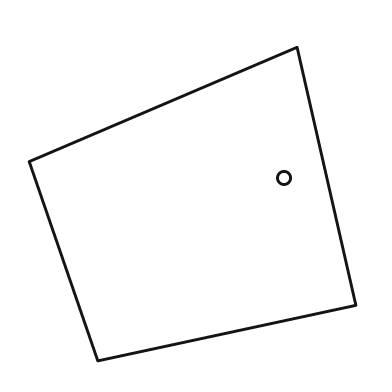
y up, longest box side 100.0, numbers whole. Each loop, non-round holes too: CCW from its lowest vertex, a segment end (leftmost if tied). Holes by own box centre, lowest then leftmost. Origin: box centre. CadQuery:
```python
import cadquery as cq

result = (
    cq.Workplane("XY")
    .moveTo(-29.0, -48.0)
    .lineTo(50.0, -31.0)
    .lineTo(32.0, 48.0)
    .lineTo(-50.0, 13.0)
    .close()
    .moveTo(28.0, 8.0)
    .circle(2.0)
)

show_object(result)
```